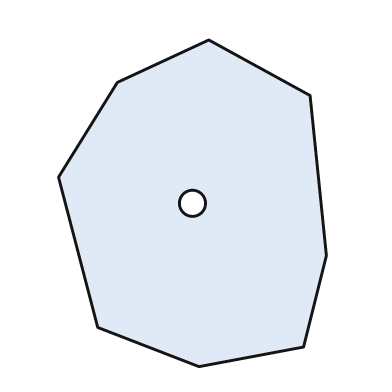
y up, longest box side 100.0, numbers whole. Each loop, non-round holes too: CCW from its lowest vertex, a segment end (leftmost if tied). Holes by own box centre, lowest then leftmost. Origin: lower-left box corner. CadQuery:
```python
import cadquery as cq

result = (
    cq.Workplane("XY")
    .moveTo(43.0, 0.0)
    .lineTo(75.0, 6.0)
    .lineTo(82.0, 34.0)
    .lineTo(77.0, 83.0)
    .lineTo(46.0, 100.0)
    .lineTo(18.0, 87.0)
    .lineTo(0.0, 58.0)
    .lineTo(12.0, 12.0)
    .close()
    .moveTo(41.0, 50.0)
    .circle(4.0)
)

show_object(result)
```